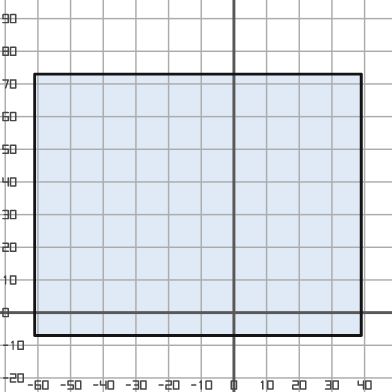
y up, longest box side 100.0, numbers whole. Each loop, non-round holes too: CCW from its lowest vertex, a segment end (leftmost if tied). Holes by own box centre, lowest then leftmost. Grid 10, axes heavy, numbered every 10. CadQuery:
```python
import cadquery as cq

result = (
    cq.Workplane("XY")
    .moveTo(-61.0, -7.0)
    .lineTo(39.0, -7.0)
    .lineTo(39.0, 73.0)
    .lineTo(-61.0, 73.0)
    .close()
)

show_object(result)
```